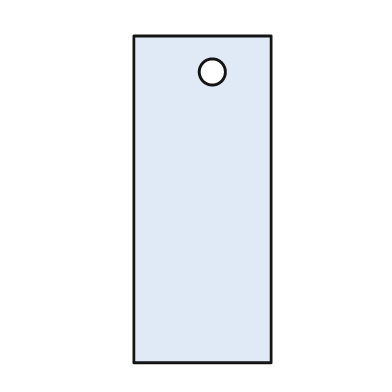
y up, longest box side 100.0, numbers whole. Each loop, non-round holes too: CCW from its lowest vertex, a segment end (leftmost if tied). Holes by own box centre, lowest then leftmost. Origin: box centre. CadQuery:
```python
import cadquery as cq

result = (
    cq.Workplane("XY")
    .moveTo(-21.0, -50.0)
    .lineTo(21.0, -50.0)
    .lineTo(21.0, 50.0)
    .lineTo(-21.0, 50.0)
    .close()
    .moveTo(3.0, 39.0)
    .circle(4.0)
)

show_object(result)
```